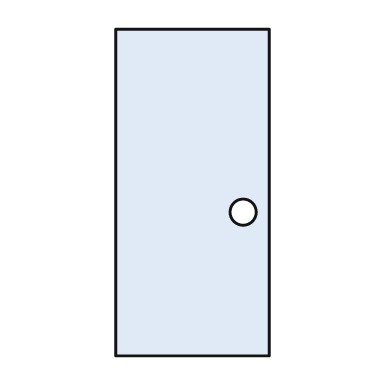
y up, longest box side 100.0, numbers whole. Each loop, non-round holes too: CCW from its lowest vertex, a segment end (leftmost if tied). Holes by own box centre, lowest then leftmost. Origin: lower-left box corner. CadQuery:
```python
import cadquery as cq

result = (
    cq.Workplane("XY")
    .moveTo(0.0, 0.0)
    .lineTo(47.0, 0.0)
    .lineTo(47.0, 100.0)
    .lineTo(0.0, 100.0)
    .close()
    .moveTo(39.0, 44.0)
    .circle(4.0)
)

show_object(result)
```